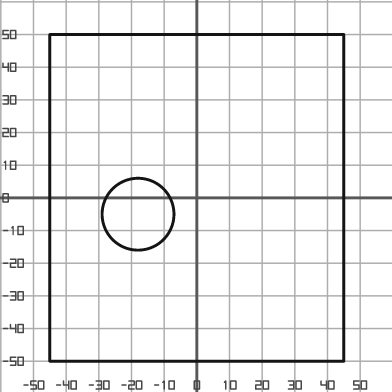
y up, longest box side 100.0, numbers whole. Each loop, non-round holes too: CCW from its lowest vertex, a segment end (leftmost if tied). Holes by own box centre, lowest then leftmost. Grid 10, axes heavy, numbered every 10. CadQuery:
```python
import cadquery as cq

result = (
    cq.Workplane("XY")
    .moveTo(-45.0, -50.0)
    .lineTo(45.0, -50.0)
    .lineTo(45.0, 50.0)
    .lineTo(-45.0, 50.0)
    .close()
    .moveTo(-18.0, -5.0)
    .circle(11.0)
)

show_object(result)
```